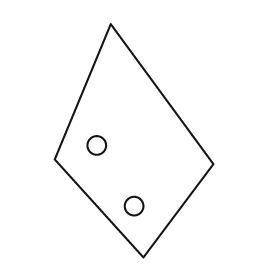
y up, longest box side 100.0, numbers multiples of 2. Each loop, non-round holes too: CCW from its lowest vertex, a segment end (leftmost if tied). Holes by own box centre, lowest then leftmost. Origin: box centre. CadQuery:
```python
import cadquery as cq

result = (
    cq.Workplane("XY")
    .moveTo(4.0, -50.0)
    .lineTo(34.0, -10.0)
    .lineTo(-10.0, 50.0)
    .lineTo(-34.0, -8.0)
    .close()
    .moveTo(0.0, -28.0)
    .circle(4.0)
    .moveTo(-16.0, -2.0)
    .circle(4.0)
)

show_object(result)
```